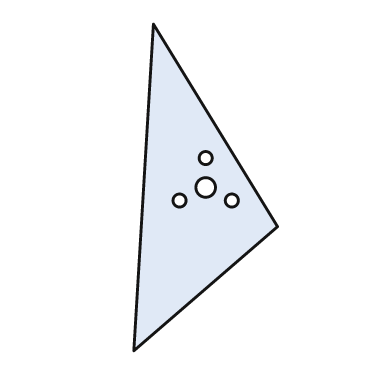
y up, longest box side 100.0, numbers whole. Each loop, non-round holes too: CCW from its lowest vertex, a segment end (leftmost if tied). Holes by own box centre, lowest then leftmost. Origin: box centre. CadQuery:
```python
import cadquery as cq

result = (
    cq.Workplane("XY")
    .moveTo(-22.0, -50.0)
    .lineTo(22.0, -12.0)
    .lineTo(-16.0, 50.0)
    .close()
    .moveTo(-8.0, -4.0)
    .circle(2.0)
    .moveTo(8.0, -4.0)
    .circle(2.0)
    .moveTo(0.0, 0.0)
    .circle(3.0)
    .moveTo(0.0, 9.0)
    .circle(2.0)
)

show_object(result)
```